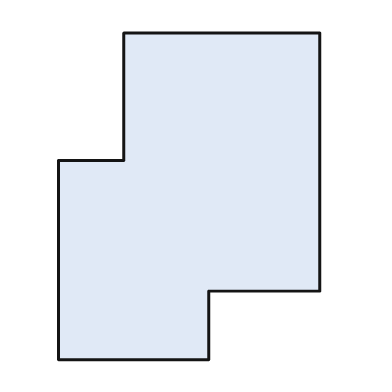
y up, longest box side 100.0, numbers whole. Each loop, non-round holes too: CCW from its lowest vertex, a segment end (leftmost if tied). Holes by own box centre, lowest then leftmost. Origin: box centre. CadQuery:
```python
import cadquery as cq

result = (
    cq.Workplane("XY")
    .moveTo(-40.0, -50.0)
    .lineTo(6.0, -50.0)
    .lineTo(6.0, -29.0)
    .lineTo(40.0, -29.0)
    .lineTo(40.0, 50.0)
    .lineTo(-20.0, 50.0)
    .lineTo(-20.0, 11.0)
    .lineTo(-40.0, 11.0)
    .close()
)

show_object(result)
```